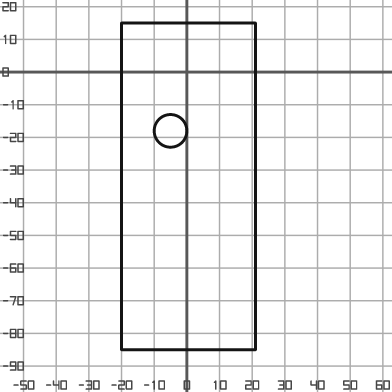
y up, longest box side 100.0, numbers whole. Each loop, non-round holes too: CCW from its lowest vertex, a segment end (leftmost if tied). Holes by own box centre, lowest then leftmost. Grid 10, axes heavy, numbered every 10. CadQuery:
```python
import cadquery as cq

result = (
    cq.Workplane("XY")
    .moveTo(-20.0, -85.0)
    .lineTo(21.0, -85.0)
    .lineTo(21.0, 15.0)
    .lineTo(-20.0, 15.0)
    .close()
    .moveTo(-5.0, -18.0)
    .circle(5.0)
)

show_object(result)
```